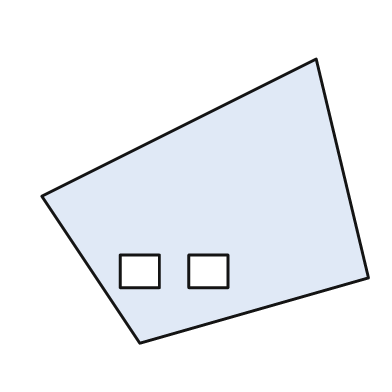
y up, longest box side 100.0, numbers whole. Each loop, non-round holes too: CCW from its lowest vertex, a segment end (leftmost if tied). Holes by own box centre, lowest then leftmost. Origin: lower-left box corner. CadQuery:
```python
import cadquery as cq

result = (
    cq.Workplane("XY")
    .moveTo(30.0, 0.0)
    .lineTo(100.0, 20.0)
    .lineTo(84.0, 87.0)
    .lineTo(0.0, 45.0)
    .close()
    .moveTo(24.0, 17.0)
    .lineTo(36.0, 17.0)
    .lineTo(36.0, 27.0)
    .lineTo(24.0, 27.0)
    .close()
    .moveTo(45.0, 17.0)
    .lineTo(57.0, 17.0)
    .lineTo(57.0, 27.0)
    .lineTo(45.0, 27.0)
    .close()
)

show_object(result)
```